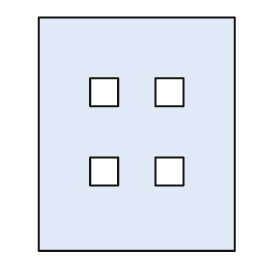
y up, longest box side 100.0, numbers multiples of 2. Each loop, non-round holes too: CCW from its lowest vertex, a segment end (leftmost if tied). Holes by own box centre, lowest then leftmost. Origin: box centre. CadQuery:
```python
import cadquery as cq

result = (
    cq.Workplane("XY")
    .moveTo(-42.0, -50.0)
    .lineTo(42.0, -50.0)
    .lineTo(42.0, 50.0)
    .lineTo(-42.0, 50.0)
    .close()
    .moveTo(-20.0, -22.0)
    .lineTo(-8.0, -22.0)
    .lineTo(-8.0, -10.0)
    .lineTo(-20.0, -10.0)
    .close()
    .moveTo(8.0, -22.0)
    .lineTo(20.0, -22.0)
    .lineTo(20.0, -10.0)
    .lineTo(8.0, -10.0)
    .close()
    .moveTo(-20.0, 12.0)
    .lineTo(-8.0, 12.0)
    .lineTo(-8.0, 24.0)
    .lineTo(-20.0, 24.0)
    .close()
    .moveTo(8.0, 12.0)
    .lineTo(20.0, 12.0)
    .lineTo(20.0, 24.0)
    .lineTo(8.0, 24.0)
    .close()
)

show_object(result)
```